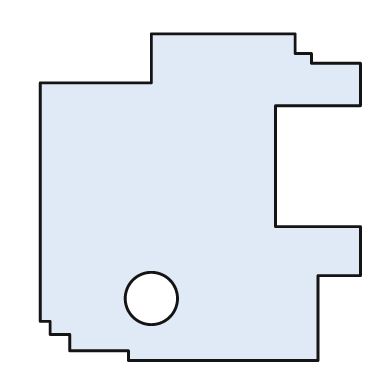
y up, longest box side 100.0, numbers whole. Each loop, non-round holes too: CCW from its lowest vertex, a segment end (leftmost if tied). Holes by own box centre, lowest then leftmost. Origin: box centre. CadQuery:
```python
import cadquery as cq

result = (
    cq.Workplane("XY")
    .moveTo(-22.0, -50.0)
    .lineTo(36.0, -50.0)
    .lineTo(36.0, -24.0)
    .lineTo(49.0, -24.0)
    .lineTo(49.0, -9.0)
    .lineTo(23.0, -9.0)
    .lineTo(23.0, 28.0)
    .lineTo(49.0, 28.0)
    .lineTo(49.0, 41.0)
    .lineTo(34.0, 41.0)
    .lineTo(34.0, 44.0)
    .lineTo(29.0, 44.0)
    .lineTo(29.0, 50.0)
    .lineTo(-15.0, 50.0)
    .lineTo(-15.0, 35.0)
    .lineTo(-49.0, 35.0)
    .lineTo(-49.0, -38.0)
    .lineTo(-46.0, -38.0)
    .lineTo(-46.0, -42.0)
    .lineTo(-40.0, -42.0)
    .lineTo(-40.0, -47.0)
    .lineTo(-22.0, -47.0)
    .close()
    .moveTo(-15.0, -31.0)
    .circle(8.0)
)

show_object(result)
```